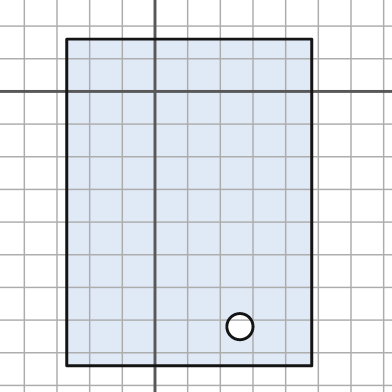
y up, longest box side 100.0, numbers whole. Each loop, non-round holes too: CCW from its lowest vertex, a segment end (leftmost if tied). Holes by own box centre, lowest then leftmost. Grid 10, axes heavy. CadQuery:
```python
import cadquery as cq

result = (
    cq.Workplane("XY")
    .moveTo(-27.0, -84.0)
    .lineTo(48.0, -84.0)
    .lineTo(48.0, 16.0)
    .lineTo(-27.0, 16.0)
    .close()
    .moveTo(26.0, -72.0)
    .circle(4.0)
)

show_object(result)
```